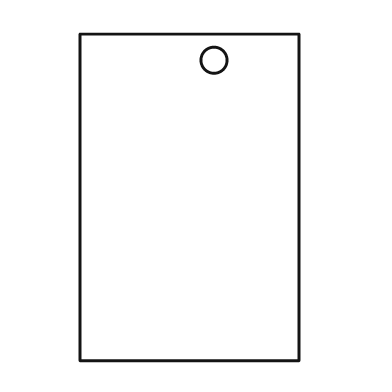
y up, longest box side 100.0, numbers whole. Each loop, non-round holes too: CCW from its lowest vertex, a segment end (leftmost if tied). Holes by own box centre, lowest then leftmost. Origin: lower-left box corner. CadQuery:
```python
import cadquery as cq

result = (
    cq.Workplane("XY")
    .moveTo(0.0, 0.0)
    .lineTo(67.0, 0.0)
    .lineTo(67.0, 100.0)
    .lineTo(0.0, 100.0)
    .close()
    .moveTo(41.0, 92.0)
    .circle(4.0)
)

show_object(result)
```